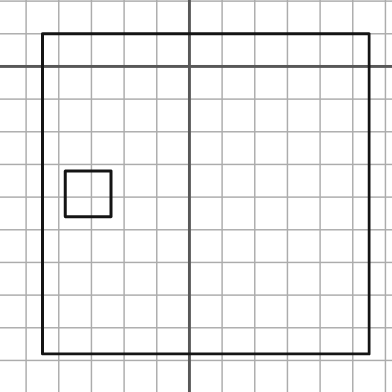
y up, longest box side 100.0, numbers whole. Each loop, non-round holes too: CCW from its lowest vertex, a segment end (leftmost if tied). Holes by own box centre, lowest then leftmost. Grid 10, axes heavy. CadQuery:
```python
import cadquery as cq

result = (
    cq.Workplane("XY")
    .moveTo(-45.0, -88.0)
    .lineTo(55.0, -88.0)
    .lineTo(55.0, 10.0)
    .lineTo(-45.0, 10.0)
    .close()
    .moveTo(-38.0, -46.0)
    .lineTo(-24.0, -46.0)
    .lineTo(-24.0, -32.0)
    .lineTo(-38.0, -32.0)
    .close()
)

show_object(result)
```